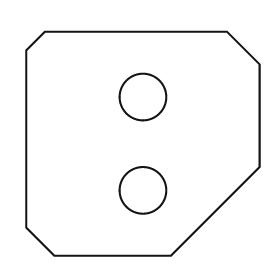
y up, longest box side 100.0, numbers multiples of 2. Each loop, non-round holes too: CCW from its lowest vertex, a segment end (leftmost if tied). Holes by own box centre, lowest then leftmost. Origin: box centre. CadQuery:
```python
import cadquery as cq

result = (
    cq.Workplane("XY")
    .moveTo(-38.0, -48.0)
    .lineTo(12.0, -48.0)
    .lineTo(50.0, -10.0)
    .lineTo(50.0, 34.0)
    .lineTo(36.0, 48.0)
    .lineTo(-42.0, 48.0)
    .lineTo(-50.0, 40.0)
    .lineTo(-50.0, -36.0)
    .close()
    .moveTo(0.0, -20.0)
    .circle(10.0)
    .moveTo(0.0, 20.0)
    .circle(10.0)
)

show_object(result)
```